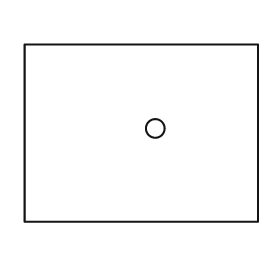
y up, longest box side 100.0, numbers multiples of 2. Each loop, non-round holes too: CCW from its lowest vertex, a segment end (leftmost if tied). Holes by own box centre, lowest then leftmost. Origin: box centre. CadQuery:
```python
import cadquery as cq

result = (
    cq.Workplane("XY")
    .moveTo(-50.0, -38.0)
    .lineTo(50.0, -38.0)
    .lineTo(50.0, 38.0)
    .lineTo(-50.0, 38.0)
    .close()
    .moveTo(6.0, 2.0)
    .circle(4.0)
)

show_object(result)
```